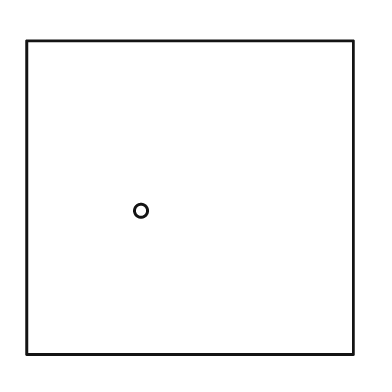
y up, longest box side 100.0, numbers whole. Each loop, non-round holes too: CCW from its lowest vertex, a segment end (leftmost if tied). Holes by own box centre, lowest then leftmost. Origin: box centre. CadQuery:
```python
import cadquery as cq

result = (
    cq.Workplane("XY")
    .moveTo(-50.0, -48.0)
    .lineTo(50.0, -48.0)
    .lineTo(50.0, 48.0)
    .lineTo(-50.0, 48.0)
    .close()
    .moveTo(-15.0, -4.0)
    .circle(2.0)
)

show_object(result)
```